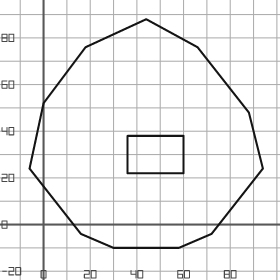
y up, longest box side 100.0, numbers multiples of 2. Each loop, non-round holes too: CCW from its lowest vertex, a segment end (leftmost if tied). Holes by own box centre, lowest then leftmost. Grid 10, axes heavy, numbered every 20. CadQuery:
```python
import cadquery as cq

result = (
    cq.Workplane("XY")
    .moveTo(30.0, -10.0)
    .lineTo(58.0, -10.0)
    .lineTo(72.0, -4.0)
    .lineTo(94.0, 24.0)
    .lineTo(88.0, 48.0)
    .lineTo(66.0, 76.0)
    .lineTo(44.0, 88.0)
    .lineTo(18.0, 76.0)
    .lineTo(0.0, 52.0)
    .lineTo(-6.0, 24.0)
    .lineTo(16.0, -4.0)
    .close()
    .moveTo(36.0, 22.0)
    .lineTo(60.0, 22.0)
    .lineTo(60.0, 38.0)
    .lineTo(36.0, 38.0)
    .close()
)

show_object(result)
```